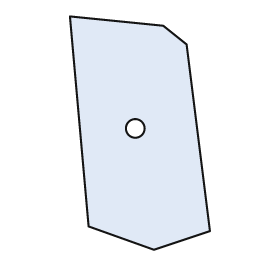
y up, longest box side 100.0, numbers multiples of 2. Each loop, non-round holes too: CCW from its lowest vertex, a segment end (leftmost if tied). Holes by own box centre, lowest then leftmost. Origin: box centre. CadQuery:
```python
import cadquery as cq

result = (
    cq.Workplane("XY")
    .moveTo(6.0, -50.0)
    .lineTo(30.0, -42.0)
    .lineTo(20.0, 38.0)
    .lineTo(10.0, 46.0)
    .lineTo(-30.0, 50.0)
    .lineTo(-22.0, -40.0)
    .close()
    .moveTo(-2.0, 2.0)
    .circle(4.0)
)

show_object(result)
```